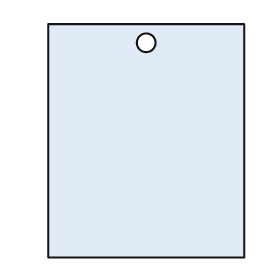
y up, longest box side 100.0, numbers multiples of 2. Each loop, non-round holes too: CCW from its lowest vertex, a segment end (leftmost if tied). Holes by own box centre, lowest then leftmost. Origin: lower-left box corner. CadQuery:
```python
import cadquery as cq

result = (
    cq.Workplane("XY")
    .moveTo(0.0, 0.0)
    .lineTo(84.0, 0.0)
    .lineTo(84.0, 100.0)
    .lineTo(0.0, 100.0)
    .close()
    .moveTo(42.0, 92.0)
    .circle(4.0)
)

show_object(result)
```